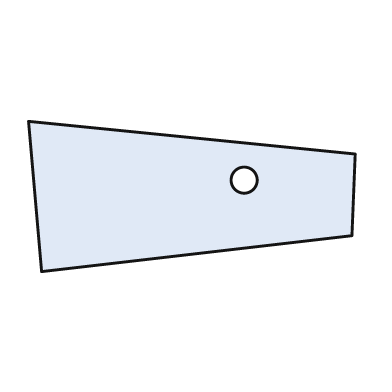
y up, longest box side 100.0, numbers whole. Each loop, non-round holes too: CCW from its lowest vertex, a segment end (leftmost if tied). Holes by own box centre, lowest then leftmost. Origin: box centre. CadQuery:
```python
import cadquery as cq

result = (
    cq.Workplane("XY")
    .moveTo(-46.0, -23.0)
    .lineTo(49.0, -12.0)
    .lineTo(50.0, 13.0)
    .lineTo(-50.0, 23.0)
    .close()
    .moveTo(16.0, 5.0)
    .circle(4.0)
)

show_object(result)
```